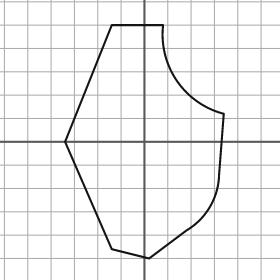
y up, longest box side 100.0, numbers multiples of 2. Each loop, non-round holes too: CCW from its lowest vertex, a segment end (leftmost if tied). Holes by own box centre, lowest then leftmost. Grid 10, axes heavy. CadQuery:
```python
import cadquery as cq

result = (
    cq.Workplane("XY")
    .moveTo(2.0, -50.0)
    .lineTo(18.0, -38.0)
    .threePointArc((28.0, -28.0), (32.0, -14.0))
    .lineTo(34.0, 12.0)
    .threePointArc((14.0, 26.0), (8.0, 50.0))
    .lineTo(-14.0, 50.0)
    .lineTo(-34.0, 0.0)
    .lineTo(-14.0, -46.0)
    .close()
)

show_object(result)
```